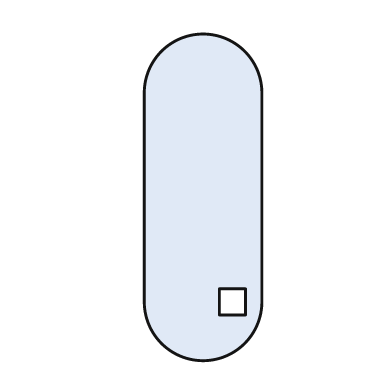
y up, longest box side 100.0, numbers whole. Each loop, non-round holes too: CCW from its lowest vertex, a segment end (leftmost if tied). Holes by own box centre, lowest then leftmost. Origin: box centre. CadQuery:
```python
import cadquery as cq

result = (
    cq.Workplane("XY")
    .moveTo(-18.0, -32.0)
    .threePointArc((0.0, -50.0), (18.0, -32.0))
    .lineTo(18.0, 32.0)
    .threePointArc((0.0, 50.0), (-18.0, 32.0))
    .close()
    .moveTo(5.0, -36.0)
    .lineTo(13.0, -36.0)
    .lineTo(13.0, -28.0)
    .lineTo(5.0, -28.0)
    .close()
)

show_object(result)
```